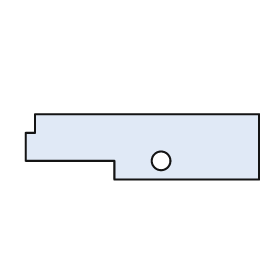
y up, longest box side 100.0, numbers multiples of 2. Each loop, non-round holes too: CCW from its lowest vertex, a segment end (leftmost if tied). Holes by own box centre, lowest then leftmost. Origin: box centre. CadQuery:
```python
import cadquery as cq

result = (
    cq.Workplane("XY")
    .moveTo(-12.0, -14.0)
    .lineTo(50.0, -14.0)
    .lineTo(50.0, 14.0)
    .lineTo(-46.0, 14.0)
    .lineTo(-46.0, 6.0)
    .lineTo(-50.0, 6.0)
    .lineTo(-50.0, -6.0)
    .lineTo(-12.0, -6.0)
    .close()
    .moveTo(8.0, -6.0)
    .circle(4.0)
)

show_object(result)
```